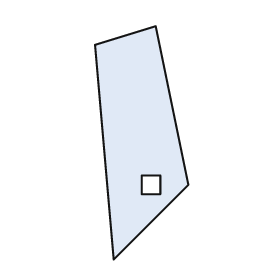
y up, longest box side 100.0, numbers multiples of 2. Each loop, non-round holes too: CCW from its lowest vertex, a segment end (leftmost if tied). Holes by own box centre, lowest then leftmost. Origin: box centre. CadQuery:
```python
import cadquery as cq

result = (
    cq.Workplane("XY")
    .moveTo(-12.0, -50.0)
    .lineTo(20.0, -18.0)
    .lineTo(6.0, 50.0)
    .lineTo(-20.0, 42.0)
    .close()
    .moveTo(0.0, -22.0)
    .lineTo(8.0, -22.0)
    .lineTo(8.0, -14.0)
    .lineTo(0.0, -14.0)
    .close()
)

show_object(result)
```